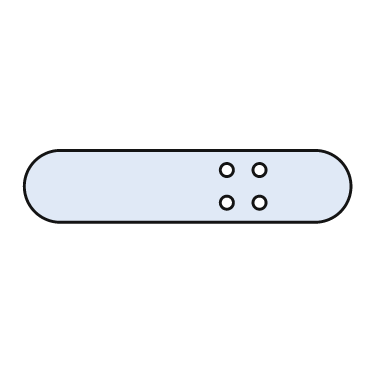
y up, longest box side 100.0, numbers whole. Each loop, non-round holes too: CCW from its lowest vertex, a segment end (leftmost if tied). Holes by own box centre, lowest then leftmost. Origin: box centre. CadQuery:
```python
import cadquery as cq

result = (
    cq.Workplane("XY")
    .moveTo(-39.0, -11.0)
    .lineTo(39.0, -11.0)
    .threePointArc((50.0, 0.0), (39.0, 11.0))
    .lineTo(-39.0, 11.0)
    .threePointArc((-50.0, 0.0), (-39.0, -11.0))
    .close()
    .moveTo(12.0, -5.0)
    .circle(2.0)
    .moveTo(22.0, -5.0)
    .circle(2.0)
    .moveTo(12.0, 5.0)
    .circle(2.0)
    .moveTo(22.0, 5.0)
    .circle(2.0)
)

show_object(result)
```